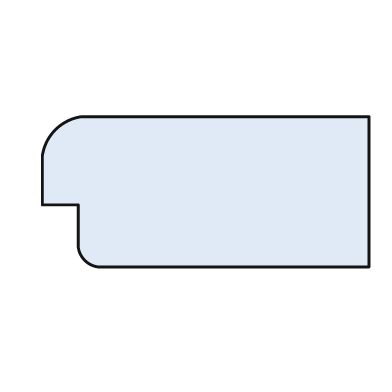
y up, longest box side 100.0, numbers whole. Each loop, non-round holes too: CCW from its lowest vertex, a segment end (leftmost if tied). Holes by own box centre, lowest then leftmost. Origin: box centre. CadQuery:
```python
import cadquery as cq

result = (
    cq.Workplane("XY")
    .moveTo(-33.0, -23.0)
    .lineTo(50.0, -23.0)
    .lineTo(50.0, 23.0)
    .lineTo(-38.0, 23.0)
    .threePointArc((-46.0, 19.0), (-50.0, 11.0))
    .lineTo(-50.0, -4.0)
    .lineTo(-39.0, -4.0)
    .lineTo(-39.0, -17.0)
    .threePointArc((-37.0, -21.0), (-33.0, -23.0))
    .close()
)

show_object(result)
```